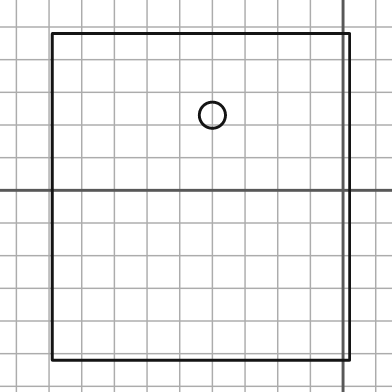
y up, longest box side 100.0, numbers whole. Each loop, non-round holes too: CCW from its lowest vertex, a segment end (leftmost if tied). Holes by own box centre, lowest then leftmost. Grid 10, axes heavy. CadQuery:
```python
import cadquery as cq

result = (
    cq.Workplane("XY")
    .moveTo(-89.0, -52.0)
    .lineTo(2.0, -52.0)
    .lineTo(2.0, 48.0)
    .lineTo(-89.0, 48.0)
    .close()
    .moveTo(-40.0, 23.0)
    .circle(4.0)
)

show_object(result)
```